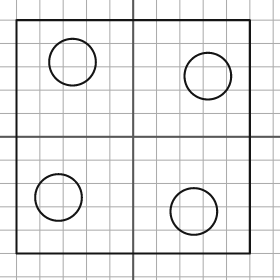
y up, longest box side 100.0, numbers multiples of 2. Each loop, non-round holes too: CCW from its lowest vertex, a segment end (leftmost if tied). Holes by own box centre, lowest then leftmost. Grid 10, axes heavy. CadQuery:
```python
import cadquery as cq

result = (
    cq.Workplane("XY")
    .moveTo(-50.0, -50.0)
    .lineTo(50.0, -50.0)
    .lineTo(50.0, 50.0)
    .lineTo(-50.0, 50.0)
    .close()
    .moveTo(26.0, -32.0)
    .circle(10.0)
    .moveTo(-32.0, -26.0)
    .circle(10.0)
    .moveTo(32.0, 26.0)
    .circle(10.0)
    .moveTo(-26.0, 32.0)
    .circle(10.0)
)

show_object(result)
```